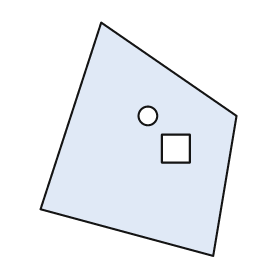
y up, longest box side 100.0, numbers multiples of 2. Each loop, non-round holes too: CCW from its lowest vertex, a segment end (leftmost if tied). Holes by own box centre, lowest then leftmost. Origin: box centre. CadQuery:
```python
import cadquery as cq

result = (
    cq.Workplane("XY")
    .moveTo(32.0, -50.0)
    .lineTo(42.0, 10.0)
    .lineTo(-16.0, 50.0)
    .lineTo(-42.0, -30.0)
    .close()
    .moveTo(10.0, -10.0)
    .lineTo(22.0, -10.0)
    .lineTo(22.0, 2.0)
    .lineTo(10.0, 2.0)
    .close()
    .moveTo(4.0, 10.0)
    .circle(4.0)
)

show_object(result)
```